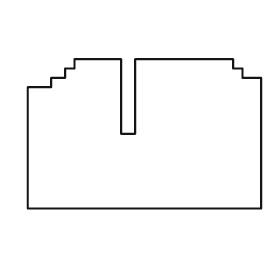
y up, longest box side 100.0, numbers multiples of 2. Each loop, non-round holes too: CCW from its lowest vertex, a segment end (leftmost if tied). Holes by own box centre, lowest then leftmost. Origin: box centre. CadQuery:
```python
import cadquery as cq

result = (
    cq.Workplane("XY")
    .moveTo(-50.0, -32.0)
    .lineTo(50.0, -32.0)
    .lineTo(50.0, 24.0)
    .lineTo(42.0, 24.0)
    .lineTo(42.0, 28.0)
    .lineTo(38.0, 28.0)
    .lineTo(38.0, 32.0)
    .lineTo(-4.0, 32.0)
    .lineTo(-4.0, 0.0)
    .lineTo(-10.0, 0.0)
    .lineTo(-10.0, 32.0)
    .lineTo(-30.0, 32.0)
    .lineTo(-30.0, 28.0)
    .lineTo(-34.0, 28.0)
    .lineTo(-34.0, 24.0)
    .lineTo(-40.0, 24.0)
    .lineTo(-40.0, 20.0)
    .lineTo(-50.0, 20.0)
    .close()
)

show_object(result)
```